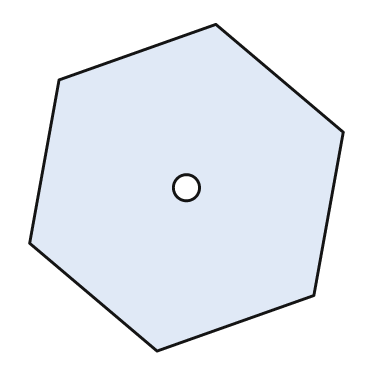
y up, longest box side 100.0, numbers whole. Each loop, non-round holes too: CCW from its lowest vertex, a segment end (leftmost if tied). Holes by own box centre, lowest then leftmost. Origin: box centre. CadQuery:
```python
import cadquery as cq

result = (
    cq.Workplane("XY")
    .moveTo(-9.0, -50.0)
    .lineTo(39.0, -33.0)
    .lineTo(48.0, 17.0)
    .lineTo(9.0, 50.0)
    .lineTo(-39.0, 33.0)
    .lineTo(-48.0, -17.0)
    .close()
    .moveTo(0.0, 0.0)
    .circle(4.0)
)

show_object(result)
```